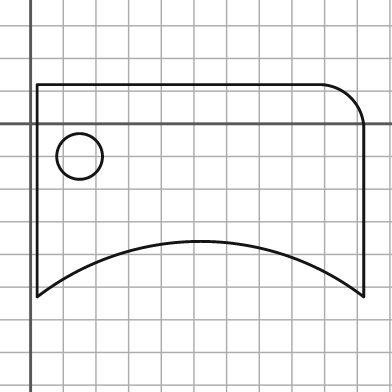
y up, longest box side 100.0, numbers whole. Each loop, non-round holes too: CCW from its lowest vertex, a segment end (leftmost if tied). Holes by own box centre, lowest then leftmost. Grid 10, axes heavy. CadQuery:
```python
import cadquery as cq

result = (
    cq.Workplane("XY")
    .moveTo(2.0, -53.0)
    .threePointArc((52.0, -36.0), (102.0, -53.0))
    .lineTo(102.0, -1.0)
    .threePointArc((98.0, 8.0), (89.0, 12.0))
    .lineTo(2.0, 12.0)
    .close()
    .moveTo(15.0, -10.0)
    .circle(7.0)
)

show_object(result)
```